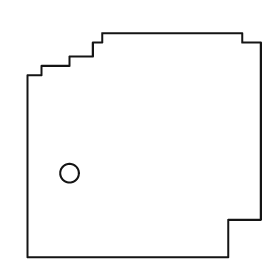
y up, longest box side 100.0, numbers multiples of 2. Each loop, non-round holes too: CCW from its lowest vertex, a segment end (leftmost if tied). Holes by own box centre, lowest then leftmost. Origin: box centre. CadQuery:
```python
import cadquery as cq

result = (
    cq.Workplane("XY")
    .moveTo(-50.0, -48.0)
    .lineTo(36.0, -48.0)
    .lineTo(36.0, -32.0)
    .lineTo(50.0, -32.0)
    .lineTo(50.0, 44.0)
    .lineTo(42.0, 44.0)
    .lineTo(42.0, 48.0)
    .lineTo(-18.0, 48.0)
    .lineTo(-18.0, 44.0)
    .lineTo(-22.0, 44.0)
    .lineTo(-22.0, 38.0)
    .lineTo(-32.0, 38.0)
    .lineTo(-32.0, 34.0)
    .lineTo(-44.0, 34.0)
    .lineTo(-44.0, 30.0)
    .lineTo(-50.0, 30.0)
    .close()
    .moveTo(-32.0, -12.0)
    .circle(4.0)
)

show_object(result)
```